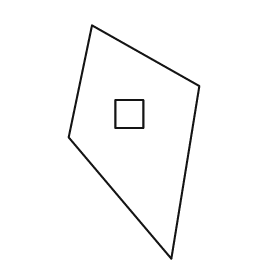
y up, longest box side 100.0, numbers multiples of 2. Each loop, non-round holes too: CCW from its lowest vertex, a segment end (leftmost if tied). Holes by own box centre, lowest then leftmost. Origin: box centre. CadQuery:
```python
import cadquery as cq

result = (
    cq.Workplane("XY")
    .moveTo(16.0, -50.0)
    .lineTo(28.0, 24.0)
    .lineTo(-18.0, 50.0)
    .lineTo(-28.0, 2.0)
    .close()
    .moveTo(-8.0, 6.0)
    .lineTo(4.0, 6.0)
    .lineTo(4.0, 18.0)
    .lineTo(-8.0, 18.0)
    .close()
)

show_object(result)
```